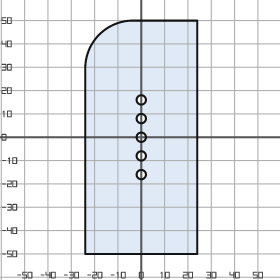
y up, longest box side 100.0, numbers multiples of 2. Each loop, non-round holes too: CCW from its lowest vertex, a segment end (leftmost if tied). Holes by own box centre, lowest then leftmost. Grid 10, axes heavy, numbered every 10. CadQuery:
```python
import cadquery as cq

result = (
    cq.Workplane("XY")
    .moveTo(-24.0, -50.0)
    .lineTo(24.0, -50.0)
    .lineTo(24.0, 50.0)
    .lineTo(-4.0, 50.0)
    .threePointArc((-18.0, 44.0), (-24.0, 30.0))
    .close()
    .moveTo(0.0, -16.0)
    .circle(2.0)
    .moveTo(0.0, -8.0)
    .circle(2.0)
    .moveTo(0.0, 0.0)
    .circle(2.0)
    .moveTo(0.0, 8.0)
    .circle(2.0)
    .moveTo(0.0, 16.0)
    .circle(2.0)
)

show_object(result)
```